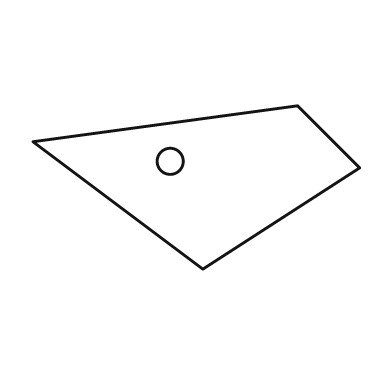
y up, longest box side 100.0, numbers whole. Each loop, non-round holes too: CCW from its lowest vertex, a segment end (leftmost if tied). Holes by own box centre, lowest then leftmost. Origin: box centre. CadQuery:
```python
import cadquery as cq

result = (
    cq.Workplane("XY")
    .moveTo(2.0, -25.0)
    .lineTo(50.0, 6.0)
    .lineTo(31.0, 25.0)
    .lineTo(-50.0, 14.0)
    .close()
    .moveTo(-8.0, 8.0)
    .circle(4.0)
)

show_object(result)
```